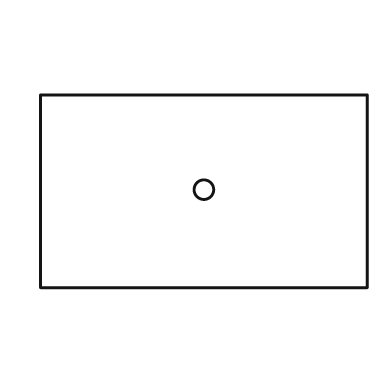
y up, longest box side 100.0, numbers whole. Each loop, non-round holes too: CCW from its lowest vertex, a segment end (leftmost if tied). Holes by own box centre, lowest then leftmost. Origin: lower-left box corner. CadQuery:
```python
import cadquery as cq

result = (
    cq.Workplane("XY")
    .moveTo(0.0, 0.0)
    .lineTo(100.0, 0.0)
    .lineTo(100.0, 59.0)
    .lineTo(0.0, 59.0)
    .close()
    .moveTo(50.0, 30.0)
    .circle(3.0)
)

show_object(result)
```